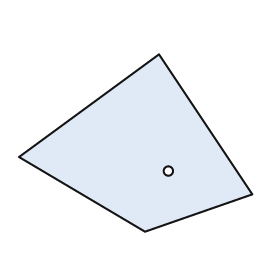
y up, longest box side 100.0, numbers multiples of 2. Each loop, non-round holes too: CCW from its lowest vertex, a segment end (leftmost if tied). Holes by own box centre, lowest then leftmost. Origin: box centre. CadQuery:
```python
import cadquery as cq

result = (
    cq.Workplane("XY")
    .moveTo(4.0, -38.0)
    .lineTo(50.0, -22.0)
    .lineTo(10.0, 38.0)
    .lineTo(-50.0, -6.0)
    .close()
    .moveTo(14.0, -12.0)
    .circle(2.0)
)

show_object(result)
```